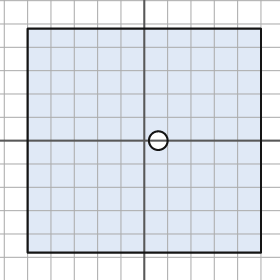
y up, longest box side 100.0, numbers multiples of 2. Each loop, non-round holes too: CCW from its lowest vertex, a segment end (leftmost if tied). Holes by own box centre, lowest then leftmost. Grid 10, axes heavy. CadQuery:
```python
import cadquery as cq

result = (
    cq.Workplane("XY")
    .moveTo(-50.0, -48.0)
    .lineTo(50.0, -48.0)
    .lineTo(50.0, 48.0)
    .lineTo(-50.0, 48.0)
    .close()
    .moveTo(6.0, 0.0)
    .circle(4.0)
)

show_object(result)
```